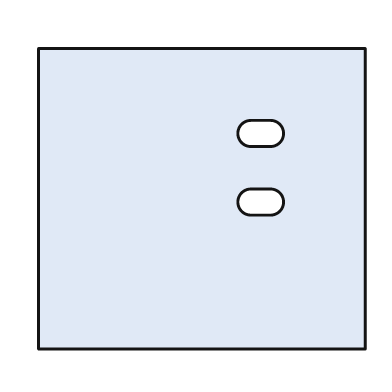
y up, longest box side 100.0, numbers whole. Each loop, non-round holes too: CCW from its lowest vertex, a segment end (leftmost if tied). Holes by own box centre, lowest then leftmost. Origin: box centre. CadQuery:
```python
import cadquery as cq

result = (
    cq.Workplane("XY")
    .moveTo(-50.0, -46.0)
    .lineTo(50.0, -46.0)
    .lineTo(50.0, 46.0)
    .lineTo(-50.0, 46.0)
    .close()
    .moveTo(15.0, -5.0)
    .lineTo(21.0, -5.0)
    .threePointArc((25.0, -1.0), (21.0, 3.0))
    .lineTo(15.0, 3.0)
    .threePointArc((11.0, -1.0), (15.0, -5.0))
    .close()
    .moveTo(15.0, 16.0)
    .lineTo(21.0, 16.0)
    .threePointArc((25.0, 20.0), (21.0, 24.0))
    .lineTo(15.0, 24.0)
    .threePointArc((11.0, 20.0), (15.0, 16.0))
    .close()
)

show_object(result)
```